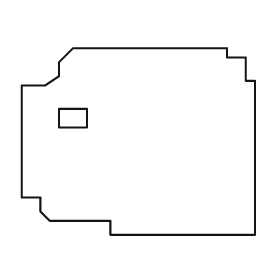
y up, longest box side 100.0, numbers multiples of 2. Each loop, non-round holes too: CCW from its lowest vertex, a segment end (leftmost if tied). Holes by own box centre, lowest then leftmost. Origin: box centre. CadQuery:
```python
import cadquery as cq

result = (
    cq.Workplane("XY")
    .moveTo(-12.0, -40.0)
    .lineTo(50.0, -40.0)
    .lineTo(50.0, 26.0)
    .lineTo(46.0, 26.0)
    .lineTo(46.0, 36.0)
    .lineTo(38.0, 36.0)
    .lineTo(38.0, 40.0)
    .lineTo(-28.0, 40.0)
    .lineTo(-34.0, 34.0)
    .lineTo(-34.0, 28.0)
    .lineTo(-40.0, 24.0)
    .lineTo(-50.0, 24.0)
    .lineTo(-50.0, -24.0)
    .lineTo(-42.0, -24.0)
    .lineTo(-42.0, -30.0)
    .lineTo(-38.0, -34.0)
    .lineTo(-12.0, -34.0)
    .close()
    .moveTo(-34.0, 6.0)
    .lineTo(-22.0, 6.0)
    .lineTo(-22.0, 14.0)
    .lineTo(-34.0, 14.0)
    .close()
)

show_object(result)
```